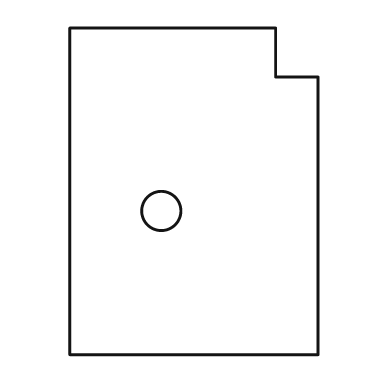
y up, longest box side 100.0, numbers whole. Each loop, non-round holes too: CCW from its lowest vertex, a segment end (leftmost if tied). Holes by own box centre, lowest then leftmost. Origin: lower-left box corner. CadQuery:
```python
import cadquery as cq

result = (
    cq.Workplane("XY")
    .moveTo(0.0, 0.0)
    .lineTo(76.0, 0.0)
    .lineTo(76.0, 85.0)
    .lineTo(63.0, 85.0)
    .lineTo(63.0, 100.0)
    .lineTo(0.0, 100.0)
    .close()
    .moveTo(28.0, 44.0)
    .circle(6.0)
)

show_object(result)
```